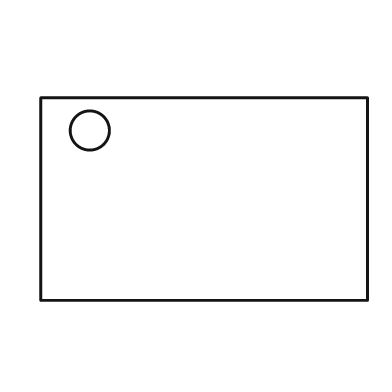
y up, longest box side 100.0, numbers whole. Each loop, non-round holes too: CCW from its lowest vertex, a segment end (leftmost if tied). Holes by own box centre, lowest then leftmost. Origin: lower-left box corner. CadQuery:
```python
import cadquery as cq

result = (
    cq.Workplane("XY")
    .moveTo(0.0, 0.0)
    .lineTo(100.0, 0.0)
    .lineTo(100.0, 62.0)
    .lineTo(0.0, 62.0)
    .close()
    .moveTo(15.0, 52.0)
    .circle(6.0)
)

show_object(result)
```